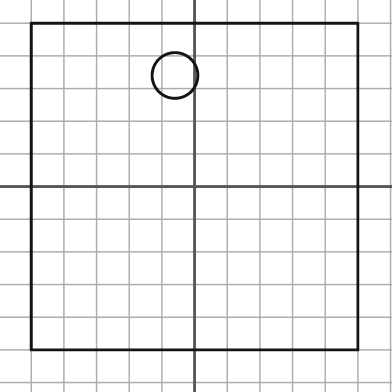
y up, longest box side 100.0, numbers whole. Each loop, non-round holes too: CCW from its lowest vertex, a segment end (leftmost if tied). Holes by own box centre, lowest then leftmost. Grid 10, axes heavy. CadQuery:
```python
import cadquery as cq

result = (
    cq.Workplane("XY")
    .moveTo(-50.0, -50.0)
    .lineTo(50.0, -50.0)
    .lineTo(50.0, 50.0)
    .lineTo(-50.0, 50.0)
    .close()
    .moveTo(-6.0, 34.0)
    .circle(7.0)
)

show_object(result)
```